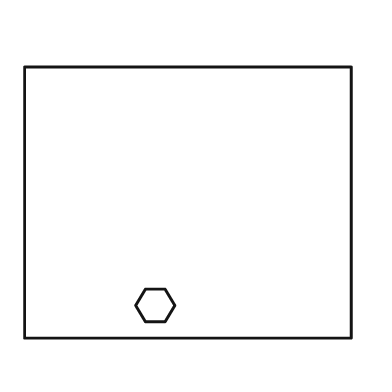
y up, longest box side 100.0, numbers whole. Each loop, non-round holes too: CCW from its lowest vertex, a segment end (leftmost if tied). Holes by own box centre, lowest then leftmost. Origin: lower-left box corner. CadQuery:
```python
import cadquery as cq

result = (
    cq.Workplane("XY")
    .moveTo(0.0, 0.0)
    .lineTo(100.0, 0.0)
    .lineTo(100.0, 83.0)
    .lineTo(0.0, 83.0)
    .close()
    .moveTo(37.0, 5.0)
    .lineTo(43.0, 5.0)
    .lineTo(46.0, 10.0)
    .lineTo(43.0, 15.0)
    .lineTo(37.0, 15.0)
    .lineTo(34.0, 10.0)
    .close()
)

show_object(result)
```